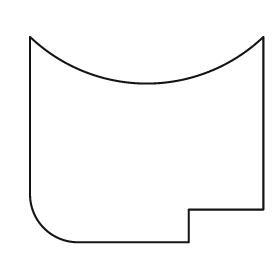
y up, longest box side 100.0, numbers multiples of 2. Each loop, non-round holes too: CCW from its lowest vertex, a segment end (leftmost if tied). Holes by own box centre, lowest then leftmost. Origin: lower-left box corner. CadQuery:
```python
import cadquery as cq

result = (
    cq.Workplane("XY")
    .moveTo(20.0, 0.0)
    .lineTo(68.0, 0.0)
    .lineTo(68.0, 14.0)
    .lineTo(100.0, 14.0)
    .lineTo(100.0, 88.0)
    .threePointArc((50.0, 68.0), (0.0, 88.0))
    .lineTo(0.0, 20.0)
    .threePointArc((6.0, 6.0), (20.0, 0.0))
    .close()
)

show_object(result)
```